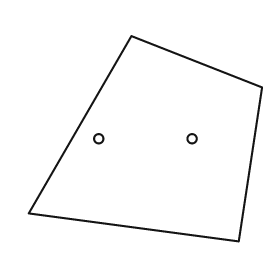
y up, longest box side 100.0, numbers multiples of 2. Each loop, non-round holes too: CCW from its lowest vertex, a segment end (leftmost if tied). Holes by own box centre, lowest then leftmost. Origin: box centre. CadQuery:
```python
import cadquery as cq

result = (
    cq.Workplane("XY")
    .moveTo(40.0, -44.0)
    .lineTo(50.0, 22.0)
    .lineTo(-6.0, 44.0)
    .lineTo(-50.0, -32.0)
    .close()
    .moveTo(-20.0, 0.0)
    .circle(2.0)
    .moveTo(20.0, 0.0)
    .circle(2.0)
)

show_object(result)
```